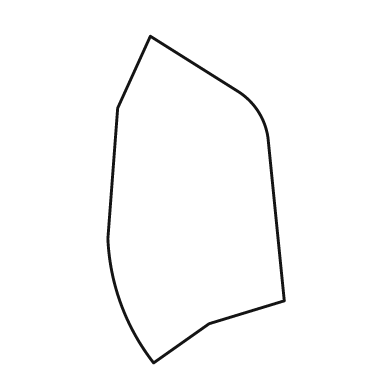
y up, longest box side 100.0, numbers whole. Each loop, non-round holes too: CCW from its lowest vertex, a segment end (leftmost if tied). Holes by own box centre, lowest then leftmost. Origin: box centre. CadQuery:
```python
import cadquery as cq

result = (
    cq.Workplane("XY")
    .moveTo(-13.0, -50.0)
    .lineTo(4.0, -38.0)
    .lineTo(27.0, -31.0)
    .lineTo(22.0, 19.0)
    .threePointArc((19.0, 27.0), (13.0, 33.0))
    .lineTo(-14.0, 50.0)
    .lineTo(-24.0, 28.0)
    .lineTo(-27.0, -12.0)
    .threePointArc((-23.0, -32.0), (-13.0, -50.0))
    .close()
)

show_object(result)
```